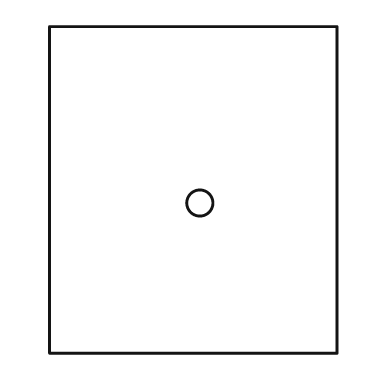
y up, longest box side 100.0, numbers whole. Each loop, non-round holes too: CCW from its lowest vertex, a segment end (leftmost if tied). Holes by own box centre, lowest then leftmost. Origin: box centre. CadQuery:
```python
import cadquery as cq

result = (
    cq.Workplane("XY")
    .moveTo(-44.0, -50.0)
    .lineTo(44.0, -50.0)
    .lineTo(44.0, 50.0)
    .lineTo(-44.0, 50.0)
    .close()
    .moveTo(2.0, -4.0)
    .circle(4.0)
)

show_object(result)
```